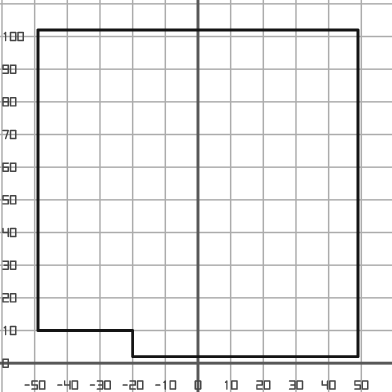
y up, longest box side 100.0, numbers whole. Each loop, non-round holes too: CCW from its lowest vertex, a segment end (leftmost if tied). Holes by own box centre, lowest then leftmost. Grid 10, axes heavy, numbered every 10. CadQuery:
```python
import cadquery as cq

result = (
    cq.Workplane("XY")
    .moveTo(-20.0, 2.0)
    .lineTo(49.0, 2.0)
    .lineTo(49.0, 102.0)
    .lineTo(-49.0, 102.0)
    .lineTo(-49.0, 10.0)
    .lineTo(-20.0, 10.0)
    .close()
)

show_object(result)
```